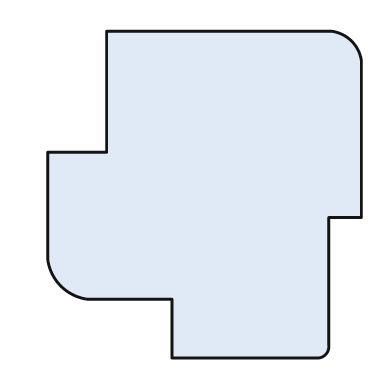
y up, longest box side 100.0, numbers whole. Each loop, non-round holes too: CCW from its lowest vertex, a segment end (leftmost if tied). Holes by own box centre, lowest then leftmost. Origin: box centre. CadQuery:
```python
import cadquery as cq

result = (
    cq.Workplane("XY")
    .moveTo(-10.0, -50.0)
    .lineTo(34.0, -50.0)
    .threePointArc((37.0, -49.0), (38.0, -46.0))
    .lineTo(38.0, -7.0)
    .lineTo(48.0, -7.0)
    .lineTo(48.0, 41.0)
    .threePointArc((45.0, 47.0), (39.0, 50.0))
    .lineTo(-30.0, 50.0)
    .lineTo(-30.0, 13.0)
    .lineTo(-48.0, 13.0)
    .lineTo(-48.0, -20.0)
    .threePointArc((-44.0, -28.0), (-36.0, -32.0))
    .lineTo(-10.0, -32.0)
    .close()
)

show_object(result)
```